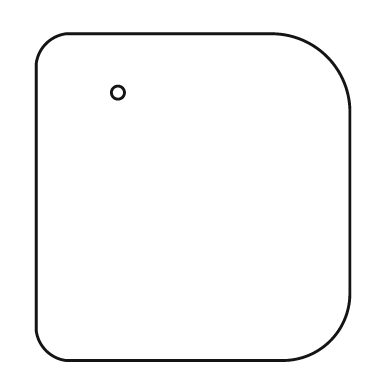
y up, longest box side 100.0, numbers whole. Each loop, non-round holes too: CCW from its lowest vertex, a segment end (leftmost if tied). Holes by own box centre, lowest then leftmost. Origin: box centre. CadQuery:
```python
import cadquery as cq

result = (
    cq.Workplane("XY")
    .moveTo(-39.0, -50.0)
    .lineTo(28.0, -50.0)
    .threePointArc((42.0, -44.0), (48.0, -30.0))
    .lineTo(48.0, 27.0)
    .threePointArc((41.0, 43.0), (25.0, 50.0))
    .lineTo(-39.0, 50.0)
    .threePointArc((-45.0, 47.0), (-48.0, 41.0))
    .lineTo(-48.0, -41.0)
    .threePointArc((-45.0, -47.0), (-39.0, -50.0))
    .close()
    .moveTo(-23.0, 32.0)
    .circle(2.0)
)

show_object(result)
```